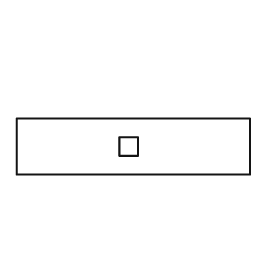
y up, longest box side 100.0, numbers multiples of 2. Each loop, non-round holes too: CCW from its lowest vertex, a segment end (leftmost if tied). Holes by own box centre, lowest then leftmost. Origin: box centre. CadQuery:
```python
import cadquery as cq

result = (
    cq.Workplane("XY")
    .moveTo(-50.0, -12.0)
    .lineTo(50.0, -12.0)
    .lineTo(50.0, 12.0)
    .lineTo(-50.0, 12.0)
    .close()
    .moveTo(-6.0, -4.0)
    .lineTo(2.0, -4.0)
    .lineTo(2.0, 4.0)
    .lineTo(-6.0, 4.0)
    .close()
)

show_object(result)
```